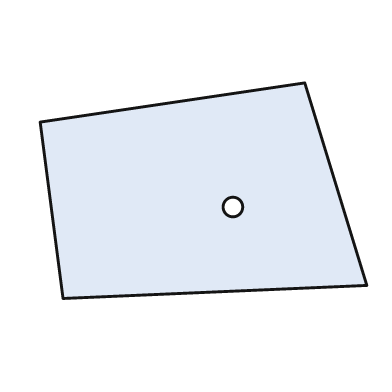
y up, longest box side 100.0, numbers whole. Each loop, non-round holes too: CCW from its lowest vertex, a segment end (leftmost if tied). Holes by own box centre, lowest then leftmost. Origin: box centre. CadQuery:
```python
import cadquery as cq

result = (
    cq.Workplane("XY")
    .moveTo(-43.0, -33.0)
    .lineTo(50.0, -29.0)
    .lineTo(31.0, 33.0)
    .lineTo(-50.0, 21.0)
    .close()
    .moveTo(9.0, -5.0)
    .circle(3.0)
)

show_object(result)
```